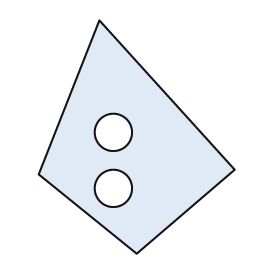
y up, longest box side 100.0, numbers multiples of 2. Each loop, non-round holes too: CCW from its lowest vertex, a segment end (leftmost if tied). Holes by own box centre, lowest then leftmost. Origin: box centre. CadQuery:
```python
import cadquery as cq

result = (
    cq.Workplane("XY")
    .moveTo(0.0, -50.0)
    .lineTo(42.0, -14.0)
    .lineTo(-16.0, 50.0)
    .lineTo(-42.0, -16.0)
    .close()
    .moveTo(-10.0, -22.0)
    .circle(8.0)
    .moveTo(-10.0, 2.0)
    .circle(8.0)
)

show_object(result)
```